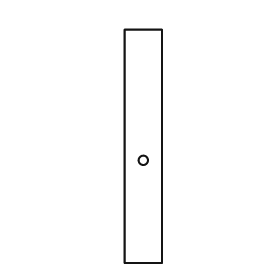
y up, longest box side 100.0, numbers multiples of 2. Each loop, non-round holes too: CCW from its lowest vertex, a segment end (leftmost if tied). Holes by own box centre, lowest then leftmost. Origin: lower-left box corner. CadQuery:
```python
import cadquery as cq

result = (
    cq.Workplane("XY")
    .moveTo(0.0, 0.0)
    .lineTo(16.0, 0.0)
    .lineTo(16.0, 100.0)
    .lineTo(0.0, 100.0)
    .close()
    .moveTo(8.0, 44.0)
    .circle(2.0)
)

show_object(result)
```